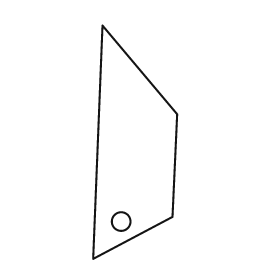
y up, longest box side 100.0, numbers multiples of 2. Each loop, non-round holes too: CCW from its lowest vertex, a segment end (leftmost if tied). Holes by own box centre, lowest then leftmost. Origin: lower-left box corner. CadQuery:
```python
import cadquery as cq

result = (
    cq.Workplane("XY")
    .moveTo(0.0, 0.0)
    .lineTo(34.0, 18.0)
    .lineTo(36.0, 62.0)
    .lineTo(4.0, 100.0)
    .close()
    .moveTo(12.0, 16.0)
    .circle(4.0)
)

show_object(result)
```